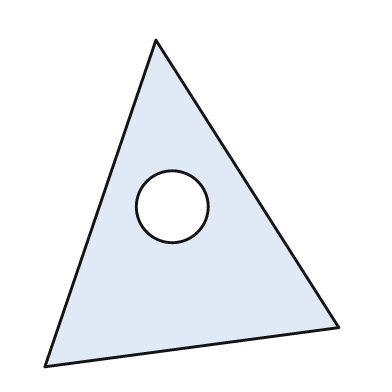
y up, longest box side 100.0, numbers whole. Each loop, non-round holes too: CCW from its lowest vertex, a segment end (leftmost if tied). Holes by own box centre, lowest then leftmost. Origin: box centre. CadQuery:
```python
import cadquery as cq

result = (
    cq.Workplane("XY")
    .moveTo(-45.0, -50.0)
    .lineTo(45.0, -38.0)
    .lineTo(-11.0, 50.0)
    .close()
    .moveTo(-6.0, -1.0)
    .circle(11.0)
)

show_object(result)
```